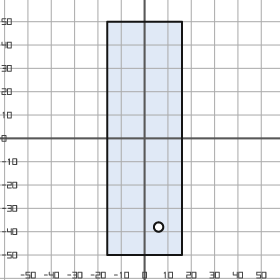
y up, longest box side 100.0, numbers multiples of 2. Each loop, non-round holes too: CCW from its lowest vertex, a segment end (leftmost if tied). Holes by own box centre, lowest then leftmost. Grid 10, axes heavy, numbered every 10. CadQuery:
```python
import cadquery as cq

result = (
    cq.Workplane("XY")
    .moveTo(-16.0, -50.0)
    .lineTo(16.0, -50.0)
    .lineTo(16.0, 50.0)
    .lineTo(-16.0, 50.0)
    .close()
    .moveTo(6.0, -38.0)
    .circle(2.0)
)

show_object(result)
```